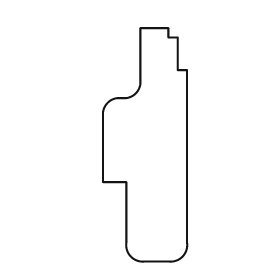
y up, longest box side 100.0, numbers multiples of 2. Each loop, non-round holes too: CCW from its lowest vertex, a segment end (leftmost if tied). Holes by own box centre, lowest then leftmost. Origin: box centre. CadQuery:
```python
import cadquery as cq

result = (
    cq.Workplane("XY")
    .moveTo(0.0, -50.0)
    .lineTo(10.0, -50.0)
    .threePointArc((16.0, -48.0), (18.0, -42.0))
    .lineTo(18.0, 32.0)
    .lineTo(14.0, 32.0)
    .lineTo(14.0, 46.0)
    .lineTo(10.0, 46.0)
    .lineTo(10.0, 50.0)
    .lineTo(-2.0, 50.0)
    .lineTo(-2.0, 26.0)
    .threePointArc((-4.0, 22.0), (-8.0, 20.0))
    .lineTo(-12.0, 20.0)
    .threePointArc((-16.0, 18.0), (-18.0, 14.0))
    .lineTo(-18.0, -16.0)
    .lineTo(-8.0, -16.0)
    .lineTo(-8.0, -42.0)
    .threePointArc((-6.0, -48.0), (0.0, -50.0))
    .close()
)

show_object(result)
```